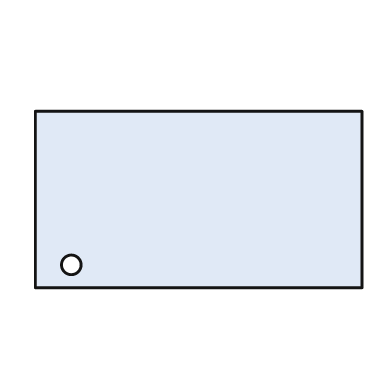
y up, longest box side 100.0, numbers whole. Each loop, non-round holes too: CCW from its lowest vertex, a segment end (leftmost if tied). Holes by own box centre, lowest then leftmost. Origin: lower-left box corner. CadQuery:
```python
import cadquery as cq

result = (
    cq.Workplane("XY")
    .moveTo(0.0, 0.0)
    .lineTo(100.0, 0.0)
    .lineTo(100.0, 54.0)
    .lineTo(0.0, 54.0)
    .close()
    .moveTo(11.0, 7.0)
    .circle(3.0)
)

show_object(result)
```